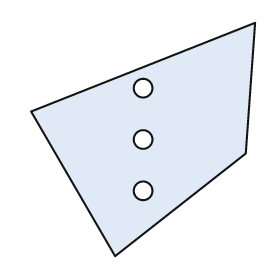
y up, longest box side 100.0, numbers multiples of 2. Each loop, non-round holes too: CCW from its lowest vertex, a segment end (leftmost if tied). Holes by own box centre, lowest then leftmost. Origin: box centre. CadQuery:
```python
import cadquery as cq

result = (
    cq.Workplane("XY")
    .moveTo(-12.0, -50.0)
    .lineTo(44.0, -6.0)
    .lineTo(48.0, 50.0)
    .lineTo(-48.0, 12.0)
    .close()
    .moveTo(0.0, -22.0)
    .circle(4.0)
    .moveTo(0.0, 0.0)
    .circle(4.0)
    .moveTo(0.0, 22.0)
    .circle(4.0)
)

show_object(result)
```